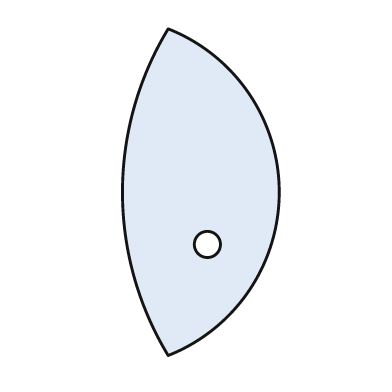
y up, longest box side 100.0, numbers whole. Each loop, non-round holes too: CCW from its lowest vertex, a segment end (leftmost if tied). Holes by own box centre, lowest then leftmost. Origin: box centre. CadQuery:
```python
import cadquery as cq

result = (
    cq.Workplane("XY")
    .moveTo(-10.0, -50.0)
    .threePointArc((24.0, 0.0), (-10.0, 50.0))
    .threePointArc((-24.0, 0.0), (-10.0, -50.0))
    .close()
    .moveTo(2.0, -16.0)
    .circle(4.0)
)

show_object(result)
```